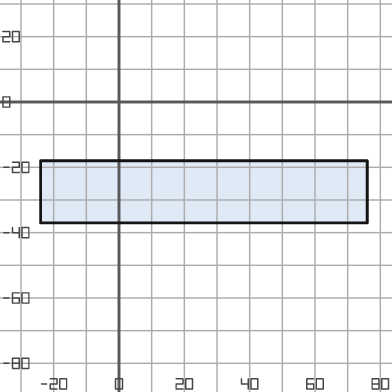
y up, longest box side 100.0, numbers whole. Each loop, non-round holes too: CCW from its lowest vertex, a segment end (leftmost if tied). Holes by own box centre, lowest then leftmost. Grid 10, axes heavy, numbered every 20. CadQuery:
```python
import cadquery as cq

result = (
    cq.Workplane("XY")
    .moveTo(-24.0, -37.0)
    .lineTo(76.0, -37.0)
    .lineTo(76.0, -18.0)
    .lineTo(-24.0, -18.0)
    .close()
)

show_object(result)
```